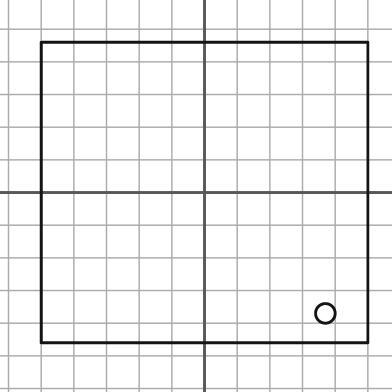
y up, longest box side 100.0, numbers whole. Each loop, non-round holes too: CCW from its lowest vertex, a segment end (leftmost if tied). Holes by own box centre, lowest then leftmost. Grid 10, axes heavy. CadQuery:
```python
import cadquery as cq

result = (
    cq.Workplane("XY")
    .moveTo(-50.0, -46.0)
    .lineTo(50.0, -46.0)
    .lineTo(50.0, 46.0)
    .lineTo(-50.0, 46.0)
    .close()
    .moveTo(37.0, -37.0)
    .circle(3.0)
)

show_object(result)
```